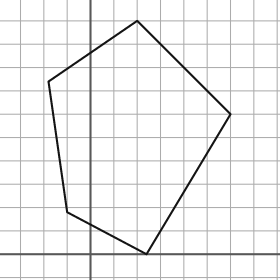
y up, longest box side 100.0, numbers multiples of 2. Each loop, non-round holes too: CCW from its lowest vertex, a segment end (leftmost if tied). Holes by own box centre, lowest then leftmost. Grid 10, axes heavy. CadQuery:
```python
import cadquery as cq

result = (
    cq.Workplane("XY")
    .moveTo(24.0, 0.0)
    .lineTo(60.0, 60.0)
    .lineTo(20.0, 100.0)
    .lineTo(-18.0, 74.0)
    .lineTo(-10.0, 18.0)
    .close()
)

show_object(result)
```